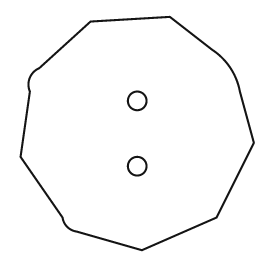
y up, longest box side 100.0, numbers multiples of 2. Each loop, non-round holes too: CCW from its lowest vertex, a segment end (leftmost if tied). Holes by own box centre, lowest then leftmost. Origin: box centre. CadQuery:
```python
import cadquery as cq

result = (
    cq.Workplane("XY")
    .moveTo(2.0, -50.0)
    .lineTo(34.0, -36.0)
    .lineTo(50.0, -4.0)
    .lineTo(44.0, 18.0)
    .threePointArc((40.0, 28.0), (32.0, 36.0))
    .lineTo(14.0, 50.0)
    .lineTo(-20.0, 48.0)
    .lineTo(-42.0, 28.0)
    .threePointArc((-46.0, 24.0), (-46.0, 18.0))
    .lineTo(-50.0, -10.0)
    .lineTo(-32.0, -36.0)
    .threePointArc((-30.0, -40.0), (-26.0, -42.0))
    .close()
    .moveTo(0.0, -14.0)
    .circle(4.0)
    .moveTo(0.0, 14.0)
    .circle(4.0)
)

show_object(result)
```